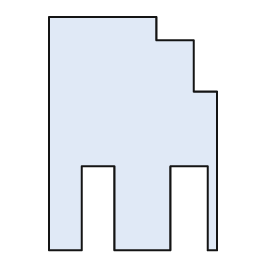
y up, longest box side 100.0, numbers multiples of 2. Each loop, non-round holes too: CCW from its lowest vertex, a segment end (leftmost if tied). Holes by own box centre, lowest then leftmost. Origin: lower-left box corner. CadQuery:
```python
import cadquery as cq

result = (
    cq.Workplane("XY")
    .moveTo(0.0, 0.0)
    .lineTo(14.0, 0.0)
    .lineTo(14.0, 36.0)
    .lineTo(28.0, 36.0)
    .lineTo(28.0, 0.0)
    .lineTo(52.0, 0.0)
    .lineTo(52.0, 36.0)
    .lineTo(68.0, 36.0)
    .lineTo(68.0, 0.0)
    .lineTo(72.0, 0.0)
    .lineTo(72.0, 68.0)
    .lineTo(62.0, 68.0)
    .lineTo(62.0, 90.0)
    .lineTo(46.0, 90.0)
    .lineTo(46.0, 100.0)
    .lineTo(0.0, 100.0)
    .close()
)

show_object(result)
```